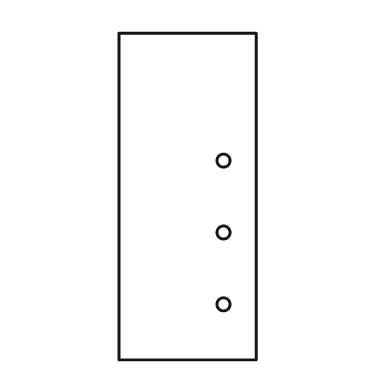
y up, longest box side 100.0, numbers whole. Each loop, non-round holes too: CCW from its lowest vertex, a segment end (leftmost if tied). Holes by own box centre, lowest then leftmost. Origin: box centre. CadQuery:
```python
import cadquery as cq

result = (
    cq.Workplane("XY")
    .moveTo(-21.0, -50.0)
    .lineTo(21.0, -50.0)
    .lineTo(21.0, 50.0)
    .lineTo(-21.0, 50.0)
    .close()
    .moveTo(11.0, -33.0)
    .circle(2.0)
    .moveTo(11.0, -11.0)
    .circle(2.0)
    .moveTo(11.0, 11.0)
    .circle(2.0)
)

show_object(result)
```